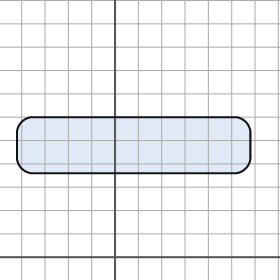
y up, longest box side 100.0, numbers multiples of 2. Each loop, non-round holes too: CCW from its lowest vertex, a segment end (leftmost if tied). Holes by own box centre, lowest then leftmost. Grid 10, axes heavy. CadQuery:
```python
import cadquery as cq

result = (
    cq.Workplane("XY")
    .moveTo(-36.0, 36.0)
    .lineTo(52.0, 36.0)
    .threePointArc((56.0, 38.0), (58.0, 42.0))
    .lineTo(58.0, 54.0)
    .threePointArc((56.0, 58.0), (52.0, 60.0))
    .lineTo(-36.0, 60.0)
    .threePointArc((-40.0, 58.0), (-42.0, 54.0))
    .lineTo(-42.0, 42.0)
    .threePointArc((-40.0, 38.0), (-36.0, 36.0))
    .close()
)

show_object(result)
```